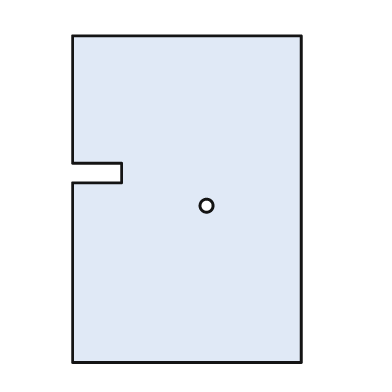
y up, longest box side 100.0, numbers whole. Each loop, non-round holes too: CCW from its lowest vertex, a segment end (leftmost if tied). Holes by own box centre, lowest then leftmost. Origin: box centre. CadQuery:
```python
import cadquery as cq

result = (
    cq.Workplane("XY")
    .moveTo(-35.0, -50.0)
    .lineTo(35.0, -50.0)
    .lineTo(35.0, 50.0)
    .lineTo(-35.0, 50.0)
    .lineTo(-35.0, 11.0)
    .lineTo(-20.0, 11.0)
    .lineTo(-20.0, 5.0)
    .lineTo(-35.0, 5.0)
    .close()
    .moveTo(6.0, -2.0)
    .circle(2.0)
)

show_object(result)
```